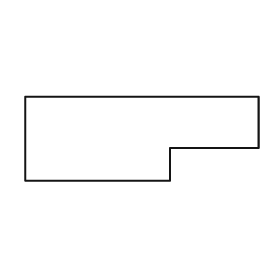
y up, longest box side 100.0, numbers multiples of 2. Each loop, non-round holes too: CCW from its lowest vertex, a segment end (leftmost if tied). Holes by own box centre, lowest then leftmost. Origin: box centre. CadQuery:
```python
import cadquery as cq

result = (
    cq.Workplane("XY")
    .moveTo(-50.0, -18.0)
    .lineTo(12.0, -18.0)
    .lineTo(12.0, -4.0)
    .lineTo(50.0, -4.0)
    .lineTo(50.0, 18.0)
    .lineTo(-50.0, 18.0)
    .close()
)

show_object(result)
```